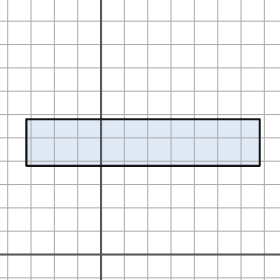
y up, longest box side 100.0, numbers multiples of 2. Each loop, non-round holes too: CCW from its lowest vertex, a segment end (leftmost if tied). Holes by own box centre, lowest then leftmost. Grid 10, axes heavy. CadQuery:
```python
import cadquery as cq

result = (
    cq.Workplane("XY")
    .moveTo(-32.0, 38.0)
    .lineTo(68.0, 38.0)
    .lineTo(68.0, 58.0)
    .lineTo(-32.0, 58.0)
    .close()
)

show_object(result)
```